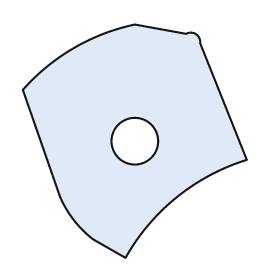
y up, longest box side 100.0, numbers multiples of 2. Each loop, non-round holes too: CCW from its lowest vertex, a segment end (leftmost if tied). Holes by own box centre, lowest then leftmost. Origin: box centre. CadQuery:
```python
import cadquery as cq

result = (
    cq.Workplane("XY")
    .moveTo(-4.0, -50.0)
    .threePointArc((18.0, -24.0), (48.0, -8.0))
    .lineTo(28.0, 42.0)
    .threePointArc((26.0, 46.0), (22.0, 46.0))
    .lineTo(0.0, 50.0)
    .threePointArc((-26.0, 40.0), (-48.0, 22.0))
    .lineTo(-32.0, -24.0)
    .threePointArc((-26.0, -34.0), (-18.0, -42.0))
    .close()
    .moveTo(0.0, 0.0)
    .circle(10.0)
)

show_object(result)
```